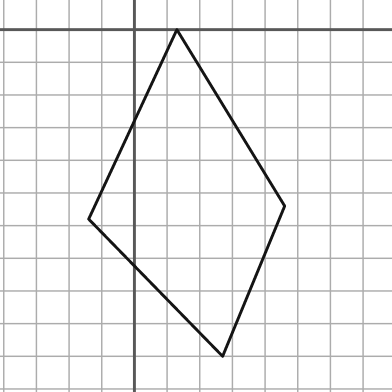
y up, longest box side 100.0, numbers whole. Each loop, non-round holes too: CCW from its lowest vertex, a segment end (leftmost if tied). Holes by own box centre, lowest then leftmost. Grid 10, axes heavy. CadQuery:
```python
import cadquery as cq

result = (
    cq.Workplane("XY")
    .moveTo(27.0, -100.0)
    .lineTo(46.0, -54.0)
    .lineTo(13.0, 0.0)
    .lineTo(-14.0, -58.0)
    .close()
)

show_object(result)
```